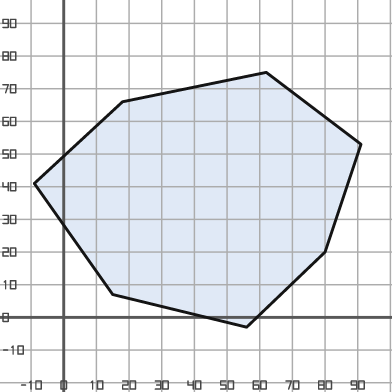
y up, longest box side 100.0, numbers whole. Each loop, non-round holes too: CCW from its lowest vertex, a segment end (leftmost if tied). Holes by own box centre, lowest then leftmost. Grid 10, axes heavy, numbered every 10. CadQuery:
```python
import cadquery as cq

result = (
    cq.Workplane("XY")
    .moveTo(56.0, -3.0)
    .lineTo(80.0, 20.0)
    .lineTo(91.0, 53.0)
    .lineTo(62.0, 75.0)
    .lineTo(18.0, 66.0)
    .lineTo(-9.0, 41.0)
    .lineTo(15.0, 7.0)
    .close()
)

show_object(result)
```